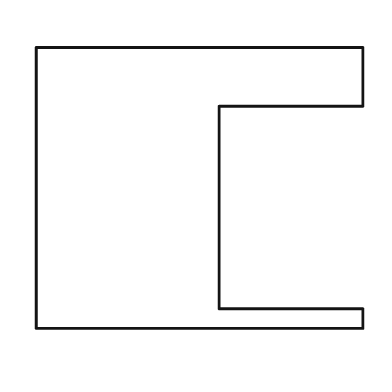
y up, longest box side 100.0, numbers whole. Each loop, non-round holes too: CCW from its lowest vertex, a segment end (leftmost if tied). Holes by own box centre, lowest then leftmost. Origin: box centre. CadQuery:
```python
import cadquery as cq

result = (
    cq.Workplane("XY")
    .moveTo(-50.0, -43.0)
    .lineTo(50.0, -43.0)
    .lineTo(50.0, -37.0)
    .lineTo(6.0, -37.0)
    .lineTo(6.0, 25.0)
    .lineTo(50.0, 25.0)
    .lineTo(50.0, 43.0)
    .lineTo(-50.0, 43.0)
    .close()
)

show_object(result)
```